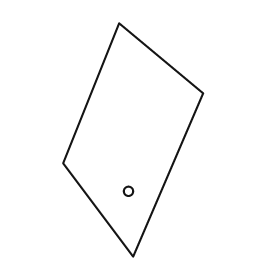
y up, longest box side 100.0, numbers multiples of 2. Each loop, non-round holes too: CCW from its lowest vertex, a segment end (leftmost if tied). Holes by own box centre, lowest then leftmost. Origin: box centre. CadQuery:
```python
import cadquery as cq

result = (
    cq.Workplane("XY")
    .moveTo(0.0, -50.0)
    .lineTo(30.0, 20.0)
    .lineTo(-6.0, 50.0)
    .lineTo(-30.0, -10.0)
    .close()
    .moveTo(-2.0, -22.0)
    .circle(2.0)
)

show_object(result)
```